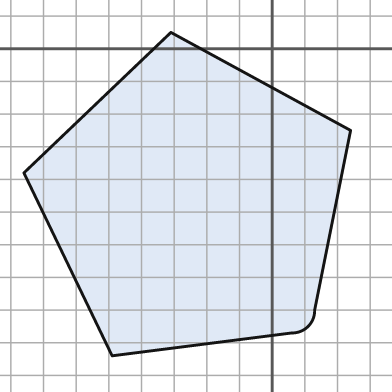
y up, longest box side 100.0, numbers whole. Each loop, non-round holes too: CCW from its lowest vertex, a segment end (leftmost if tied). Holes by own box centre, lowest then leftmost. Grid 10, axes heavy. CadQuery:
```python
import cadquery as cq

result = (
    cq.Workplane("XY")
    .moveTo(-49.0, -94.0)
    .lineTo(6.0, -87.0)
    .threePointArc((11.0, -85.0), (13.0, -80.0))
    .lineTo(24.0, -25.0)
    .lineTo(-31.0, 5.0)
    .lineTo(-76.0, -38.0)
    .close()
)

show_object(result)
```